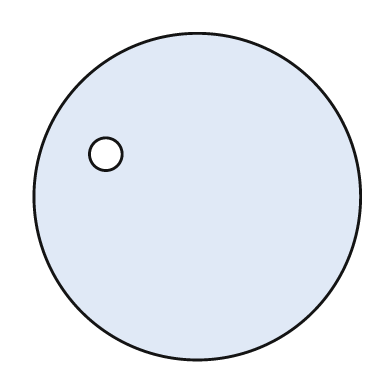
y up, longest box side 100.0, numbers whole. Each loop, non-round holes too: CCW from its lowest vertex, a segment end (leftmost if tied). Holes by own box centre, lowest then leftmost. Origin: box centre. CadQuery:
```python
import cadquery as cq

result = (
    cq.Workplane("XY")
    .moveTo(0.0, 0.0)
    .circle(50.0)
    .moveTo(-28.0, 13.0)
    .circle(5.0)
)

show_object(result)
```